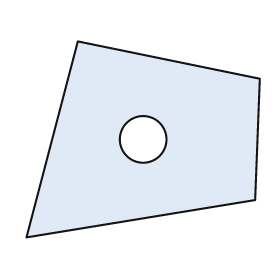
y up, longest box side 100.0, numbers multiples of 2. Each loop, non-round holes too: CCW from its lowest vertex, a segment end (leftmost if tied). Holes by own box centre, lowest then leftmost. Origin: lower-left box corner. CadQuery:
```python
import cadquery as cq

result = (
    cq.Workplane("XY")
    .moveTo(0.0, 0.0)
    .lineTo(98.0, 16.0)
    .lineTo(100.0, 68.0)
    .lineTo(22.0, 84.0)
    .close()
    .moveTo(50.0, 42.0)
    .circle(10.0)
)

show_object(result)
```